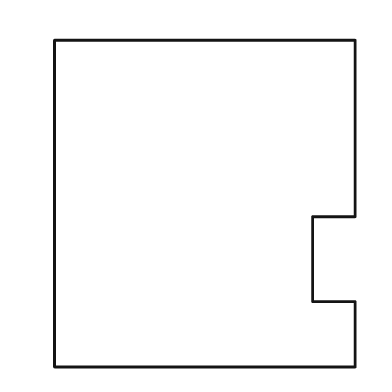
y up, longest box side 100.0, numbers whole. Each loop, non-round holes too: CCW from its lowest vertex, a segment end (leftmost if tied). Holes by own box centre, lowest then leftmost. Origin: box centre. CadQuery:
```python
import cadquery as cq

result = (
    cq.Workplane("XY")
    .moveTo(-46.0, -50.0)
    .lineTo(46.0, -50.0)
    .lineTo(46.0, -30.0)
    .lineTo(33.0, -30.0)
    .lineTo(33.0, -4.0)
    .lineTo(46.0, -4.0)
    .lineTo(46.0, 50.0)
    .lineTo(-46.0, 50.0)
    .close()
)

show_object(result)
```